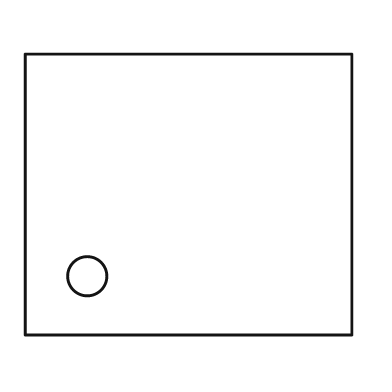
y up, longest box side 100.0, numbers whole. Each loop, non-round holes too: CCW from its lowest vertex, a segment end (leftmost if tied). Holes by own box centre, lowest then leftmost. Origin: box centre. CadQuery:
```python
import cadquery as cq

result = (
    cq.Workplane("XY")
    .moveTo(-50.0, -43.0)
    .lineTo(50.0, -43.0)
    .lineTo(50.0, 43.0)
    .lineTo(-50.0, 43.0)
    .close()
    .moveTo(-31.0, -25.0)
    .circle(6.0)
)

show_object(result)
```